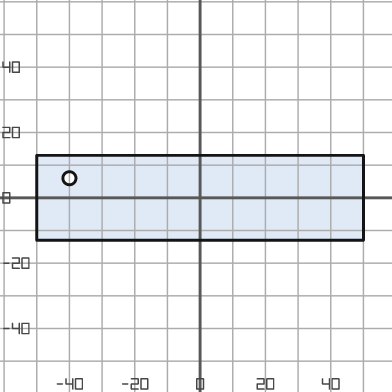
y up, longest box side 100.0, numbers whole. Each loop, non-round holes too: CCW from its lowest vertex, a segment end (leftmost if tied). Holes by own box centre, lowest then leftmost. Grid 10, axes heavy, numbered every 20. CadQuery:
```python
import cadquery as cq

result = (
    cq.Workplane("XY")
    .moveTo(-50.0, -13.0)
    .lineTo(50.0, -13.0)
    .lineTo(50.0, 13.0)
    .lineTo(-50.0, 13.0)
    .close()
    .moveTo(-40.0, 6.0)
    .circle(2.0)
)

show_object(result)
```